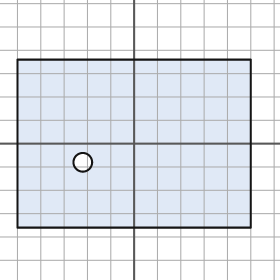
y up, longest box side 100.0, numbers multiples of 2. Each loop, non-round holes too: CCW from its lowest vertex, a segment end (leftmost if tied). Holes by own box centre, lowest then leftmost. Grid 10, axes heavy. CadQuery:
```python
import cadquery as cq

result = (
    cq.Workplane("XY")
    .moveTo(-50.0, -36.0)
    .lineTo(50.0, -36.0)
    .lineTo(50.0, 36.0)
    .lineTo(-50.0, 36.0)
    .close()
    .moveTo(-22.0, -8.0)
    .circle(4.0)
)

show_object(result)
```